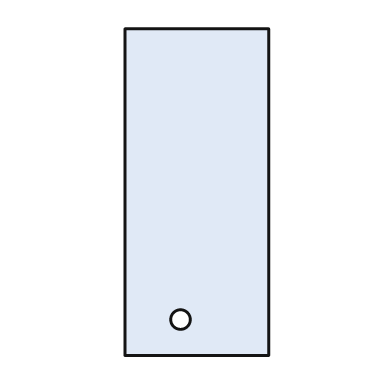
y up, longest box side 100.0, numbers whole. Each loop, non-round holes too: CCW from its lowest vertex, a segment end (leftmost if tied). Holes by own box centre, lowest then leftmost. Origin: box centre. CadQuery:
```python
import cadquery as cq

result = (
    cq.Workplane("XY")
    .moveTo(-22.0, -50.0)
    .lineTo(22.0, -50.0)
    .lineTo(22.0, 50.0)
    .lineTo(-22.0, 50.0)
    .close()
    .moveTo(-5.0, -39.0)
    .circle(3.0)
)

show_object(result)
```